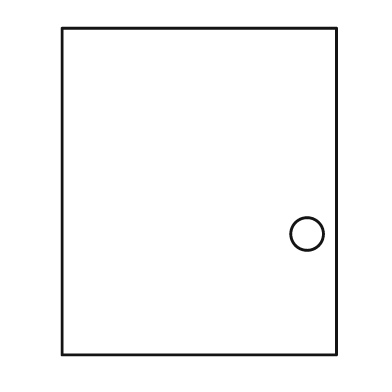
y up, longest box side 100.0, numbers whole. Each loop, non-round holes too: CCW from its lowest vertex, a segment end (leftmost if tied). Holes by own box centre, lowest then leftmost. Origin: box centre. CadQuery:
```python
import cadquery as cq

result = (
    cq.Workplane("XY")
    .moveTo(-42.0, -50.0)
    .lineTo(42.0, -50.0)
    .lineTo(42.0, 50.0)
    .lineTo(-42.0, 50.0)
    .close()
    .moveTo(33.0, -13.0)
    .circle(5.0)
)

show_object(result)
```